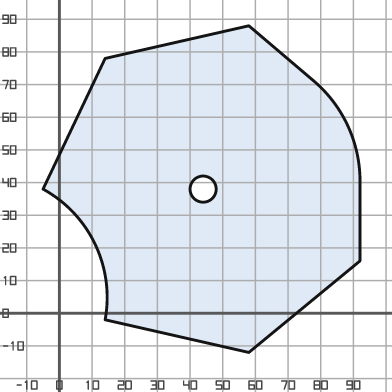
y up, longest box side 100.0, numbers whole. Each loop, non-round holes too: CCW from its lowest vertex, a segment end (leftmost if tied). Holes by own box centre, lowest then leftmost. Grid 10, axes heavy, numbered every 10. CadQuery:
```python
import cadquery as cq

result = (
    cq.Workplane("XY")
    .moveTo(58.0, -12.0)
    .lineTo(92.0, 16.0)
    .lineTo(92.0, 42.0)
    .threePointArc((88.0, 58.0), (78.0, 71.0))
    .lineTo(58.0, 88.0)
    .lineTo(14.0, 78.0)
    .lineTo(-5.0, 38.0)
    .threePointArc((11.0, 21.0), (14.0, -2.0))
    .close()
    .moveTo(44.0, 38.0)
    .circle(4.0)
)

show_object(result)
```